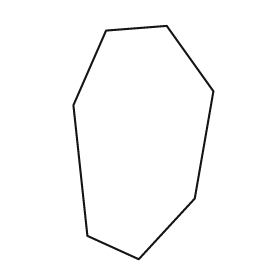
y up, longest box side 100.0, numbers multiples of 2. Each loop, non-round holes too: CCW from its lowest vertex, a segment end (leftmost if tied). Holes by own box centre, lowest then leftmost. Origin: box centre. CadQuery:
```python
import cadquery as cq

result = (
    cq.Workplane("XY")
    .moveTo(-2.0, -50.0)
    .lineTo(22.0, -24.0)
    .lineTo(30.0, 22.0)
    .lineTo(10.0, 50.0)
    .lineTo(-16.0, 48.0)
    .lineTo(-30.0, 16.0)
    .lineTo(-24.0, -40.0)
    .close()
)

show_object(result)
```